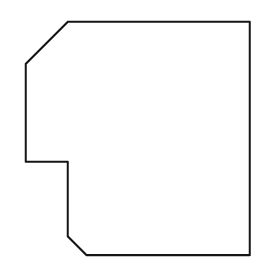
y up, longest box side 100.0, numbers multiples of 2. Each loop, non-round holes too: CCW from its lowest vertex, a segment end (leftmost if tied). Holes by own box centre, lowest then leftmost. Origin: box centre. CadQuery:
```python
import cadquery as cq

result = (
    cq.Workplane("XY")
    .moveTo(-22.0, -50.0)
    .lineTo(48.0, -50.0)
    .lineTo(48.0, 50.0)
    .lineTo(-30.0, 50.0)
    .lineTo(-48.0, 32.0)
    .lineTo(-48.0, -10.0)
    .lineTo(-30.0, -10.0)
    .lineTo(-30.0, -42.0)
    .close()
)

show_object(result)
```